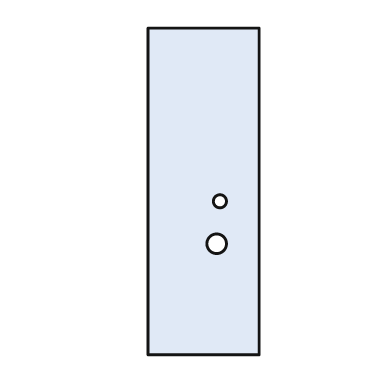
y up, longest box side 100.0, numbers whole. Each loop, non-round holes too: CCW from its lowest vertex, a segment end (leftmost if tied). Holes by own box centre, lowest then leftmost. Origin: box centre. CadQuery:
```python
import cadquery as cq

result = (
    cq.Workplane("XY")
    .moveTo(-17.0, -50.0)
    .lineTo(17.0, -50.0)
    .lineTo(17.0, 50.0)
    .lineTo(-17.0, 50.0)
    .close()
    .moveTo(4.0, -16.0)
    .circle(3.0)
    .moveTo(5.0, -3.0)
    .circle(2.0)
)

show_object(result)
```